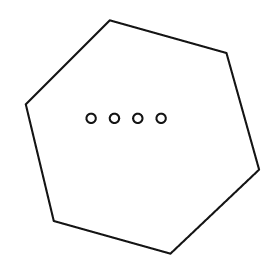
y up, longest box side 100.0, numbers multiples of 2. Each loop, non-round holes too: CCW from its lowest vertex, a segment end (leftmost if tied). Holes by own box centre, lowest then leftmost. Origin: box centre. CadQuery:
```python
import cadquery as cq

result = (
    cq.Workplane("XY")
    .moveTo(12.0, -50.0)
    .lineTo(50.0, -14.0)
    .lineTo(36.0, 36.0)
    .lineTo(-14.0, 50.0)
    .lineTo(-50.0, 14.0)
    .lineTo(-38.0, -36.0)
    .close()
    .moveTo(-22.0, 8.0)
    .circle(2.0)
    .moveTo(-12.0, 8.0)
    .circle(2.0)
    .moveTo(-2.0, 8.0)
    .circle(2.0)
    .moveTo(8.0, 8.0)
    .circle(2.0)
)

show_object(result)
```